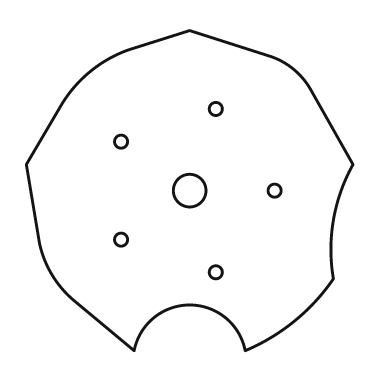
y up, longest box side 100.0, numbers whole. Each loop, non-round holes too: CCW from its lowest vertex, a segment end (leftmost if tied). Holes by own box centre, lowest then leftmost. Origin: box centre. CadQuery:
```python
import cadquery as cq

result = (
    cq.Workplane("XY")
    .moveTo(-17.0, -49.0)
    .threePointArc((0.0, -35.0), (17.0, -49.0))
    .threePointArc((32.0, -40.0), (44.0, -27.0))
    .threePointArc((44.0, -9.0), (50.0, 8.0))
    .lineTo(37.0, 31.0)
    .threePointArc((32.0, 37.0), (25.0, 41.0))
    .lineTo(0.0, 49.0)
    .lineTo(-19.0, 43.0)
    .threePointArc((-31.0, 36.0), (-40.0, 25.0))
    .lineTo(-50.0, 8.0)
    .lineTo(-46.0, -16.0)
    .threePointArc((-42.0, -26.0), (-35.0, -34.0))
    .close()
    .moveTo(8.0, -25.0)
    .circle(2.0)
    .moveTo(-21.0, -15.0)
    .circle(2.0)
    .moveTo(0.0, 0.0)
    .circle(5.0)
    .moveTo(26.0, 0.0)
    .circle(2.0)
    .moveTo(-21.0, 15.0)
    .circle(2.0)
    .moveTo(8.0, 25.0)
    .circle(2.0)
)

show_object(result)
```